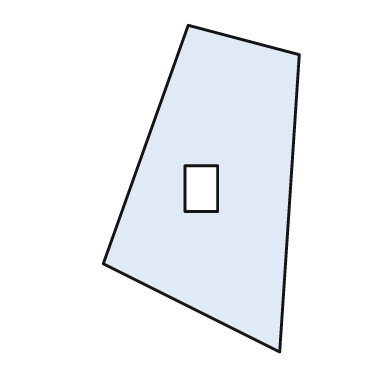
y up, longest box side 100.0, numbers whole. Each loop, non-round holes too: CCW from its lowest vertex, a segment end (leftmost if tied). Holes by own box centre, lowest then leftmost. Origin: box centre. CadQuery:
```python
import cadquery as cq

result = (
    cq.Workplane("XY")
    .moveTo(24.0, -50.0)
    .lineTo(30.0, 41.0)
    .lineTo(-4.0, 50.0)
    .lineTo(-30.0, -23.0)
    .close()
    .moveTo(-5.0, -7.0)
    .lineTo(5.0, -7.0)
    .lineTo(5.0, 7.0)
    .lineTo(-5.0, 7.0)
    .close()
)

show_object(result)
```